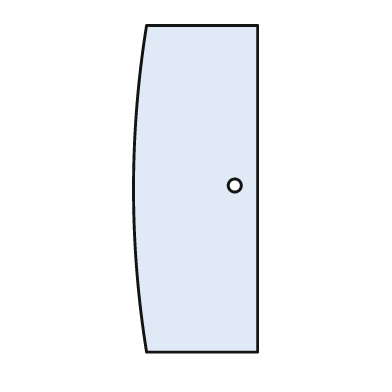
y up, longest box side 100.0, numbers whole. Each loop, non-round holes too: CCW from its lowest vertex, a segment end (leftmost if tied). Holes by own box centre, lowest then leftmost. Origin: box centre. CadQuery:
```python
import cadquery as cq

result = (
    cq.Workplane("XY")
    .moveTo(-15.0, -50.0)
    .lineTo(19.0, -50.0)
    .lineTo(19.0, 50.0)
    .lineTo(-15.0, 50.0)
    .threePointArc((-19.0, 0.0), (-15.0, -50.0))
    .close()
    .moveTo(12.0, 1.0)
    .circle(2.0)
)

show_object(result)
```